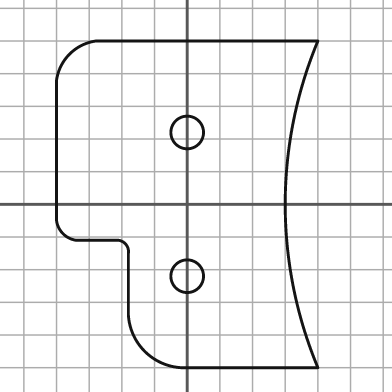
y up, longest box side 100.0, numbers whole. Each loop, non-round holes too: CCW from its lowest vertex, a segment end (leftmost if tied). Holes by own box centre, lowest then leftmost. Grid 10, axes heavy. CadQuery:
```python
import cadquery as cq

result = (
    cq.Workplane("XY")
    .moveTo(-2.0, -50.0)
    .lineTo(40.0, -50.0)
    .threePointArc((30.0, 0.0), (40.0, 50.0))
    .lineTo(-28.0, 50.0)
    .threePointArc((-36.0, 46.0), (-40.0, 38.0))
    .lineTo(-40.0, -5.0)
    .threePointArc((-38.0, -9.0), (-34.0, -11.0))
    .lineTo(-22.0, -11.0)
    .threePointArc((-19.0, -12.0), (-18.0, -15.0))
    .lineTo(-18.0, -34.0)
    .threePointArc((-13.0, -45.0), (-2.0, -50.0))
    .close()
    .moveTo(0.0, -22.0)
    .circle(5.0)
    .moveTo(0.0, 22.0)
    .circle(5.0)
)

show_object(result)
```